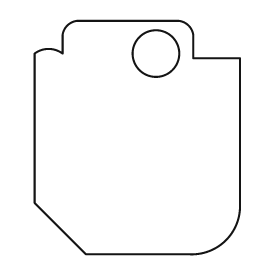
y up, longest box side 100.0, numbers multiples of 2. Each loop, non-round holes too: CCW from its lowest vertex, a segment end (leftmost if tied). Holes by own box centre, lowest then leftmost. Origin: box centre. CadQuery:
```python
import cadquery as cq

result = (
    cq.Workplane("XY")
    .moveTo(-22.0, -50.0)
    .lineTo(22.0, -50.0)
    .threePointArc((38.0, -44.0), (44.0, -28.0))
    .lineTo(44.0, 34.0)
    .lineTo(24.0, 34.0)
    .lineTo(24.0, 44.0)
    .threePointArc((22.0, 48.0), (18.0, 50.0))
    .lineTo(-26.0, 50.0)
    .threePointArc((-30.0, 48.0), (-32.0, 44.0))
    .lineTo(-32.0, 36.0)
    .threePointArc((-38.0, 38.0), (-44.0, 36.0))
    .lineTo(-44.0, -28.0)
    .close()
    .moveTo(8.0, 36.0)
    .circle(10.0)
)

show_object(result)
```